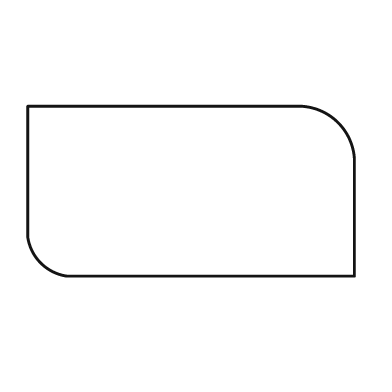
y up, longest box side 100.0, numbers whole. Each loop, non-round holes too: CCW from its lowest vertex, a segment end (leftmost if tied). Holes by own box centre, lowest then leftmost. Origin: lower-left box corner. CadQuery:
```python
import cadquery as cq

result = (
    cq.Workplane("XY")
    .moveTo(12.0, 0.0)
    .lineTo(100.0, 0.0)
    .lineTo(100.0, 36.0)
    .threePointArc((95.0, 47.0), (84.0, 52.0))
    .lineTo(0.0, 52.0)
    .lineTo(0.0, 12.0)
    .threePointArc((4.0, 4.0), (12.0, 0.0))
    .close()
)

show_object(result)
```